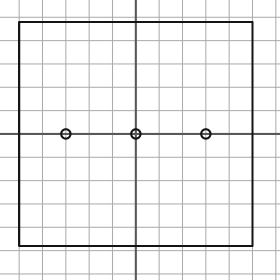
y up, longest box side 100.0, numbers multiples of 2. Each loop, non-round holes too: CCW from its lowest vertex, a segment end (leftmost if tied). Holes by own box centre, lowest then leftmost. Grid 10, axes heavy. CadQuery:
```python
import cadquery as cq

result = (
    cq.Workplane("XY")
    .moveTo(-50.0, -48.0)
    .lineTo(50.0, -48.0)
    .lineTo(50.0, 48.0)
    .lineTo(-50.0, 48.0)
    .close()
    .moveTo(-30.0, 0.0)
    .circle(2.0)
    .moveTo(0.0, 0.0)
    .circle(2.0)
    .moveTo(30.0, 0.0)
    .circle(2.0)
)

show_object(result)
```